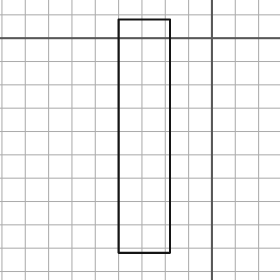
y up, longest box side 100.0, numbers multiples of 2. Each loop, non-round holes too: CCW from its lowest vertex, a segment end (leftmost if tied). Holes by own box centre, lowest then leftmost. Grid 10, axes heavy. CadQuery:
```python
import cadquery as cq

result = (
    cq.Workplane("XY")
    .moveTo(-40.0, -92.0)
    .lineTo(-18.0, -92.0)
    .lineTo(-18.0, 8.0)
    .lineTo(-40.0, 8.0)
    .close()
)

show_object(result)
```